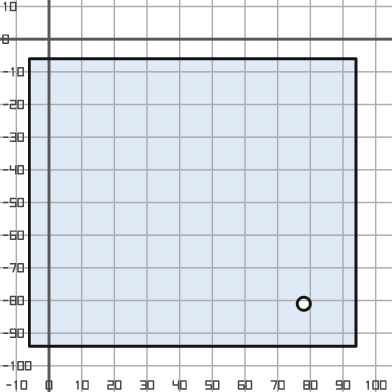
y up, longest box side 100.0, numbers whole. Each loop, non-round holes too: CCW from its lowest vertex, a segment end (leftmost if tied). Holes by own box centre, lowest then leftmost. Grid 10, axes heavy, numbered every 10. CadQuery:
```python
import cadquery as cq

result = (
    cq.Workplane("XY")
    .moveTo(-6.0, -94.0)
    .lineTo(94.0, -94.0)
    .lineTo(94.0, -6.0)
    .lineTo(-6.0, -6.0)
    .close()
    .moveTo(78.0, -81.0)
    .circle(2.0)
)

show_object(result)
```